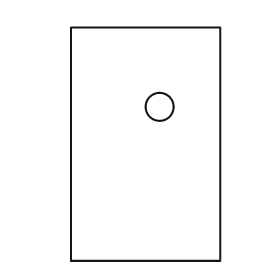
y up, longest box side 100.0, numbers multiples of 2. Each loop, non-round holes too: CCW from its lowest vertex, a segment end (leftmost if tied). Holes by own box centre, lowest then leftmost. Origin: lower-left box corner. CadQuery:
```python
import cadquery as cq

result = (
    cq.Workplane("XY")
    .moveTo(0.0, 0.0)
    .lineTo(64.0, 0.0)
    .lineTo(64.0, 100.0)
    .lineTo(0.0, 100.0)
    .close()
    .moveTo(38.0, 66.0)
    .circle(6.0)
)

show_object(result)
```